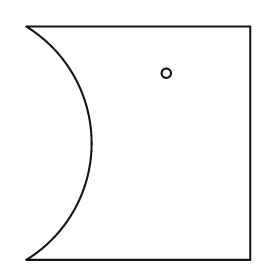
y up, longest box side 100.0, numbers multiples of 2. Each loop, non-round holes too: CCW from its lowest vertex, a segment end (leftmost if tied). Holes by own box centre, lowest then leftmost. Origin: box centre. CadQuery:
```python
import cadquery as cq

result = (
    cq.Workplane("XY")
    .moveTo(-48.0, -50.0)
    .lineTo(48.0, -50.0)
    .lineTo(48.0, 50.0)
    .lineTo(-48.0, 50.0)
    .threePointArc((-20.0, 0.0), (-48.0, -50.0))
    .close()
    .moveTo(12.0, 30.0)
    .circle(2.0)
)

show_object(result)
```